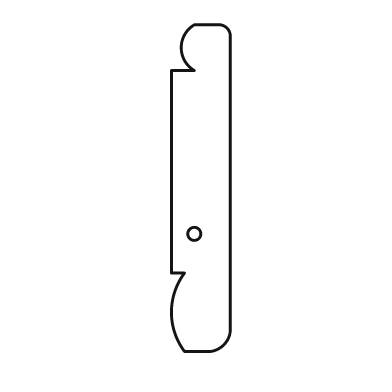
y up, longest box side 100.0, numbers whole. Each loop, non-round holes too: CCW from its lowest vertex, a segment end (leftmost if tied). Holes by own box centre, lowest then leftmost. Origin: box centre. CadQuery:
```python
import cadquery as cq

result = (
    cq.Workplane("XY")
    .moveTo(-5.0, -50.0)
    .lineTo(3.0, -50.0)
    .threePointArc((7.0, -48.0), (9.0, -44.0))
    .lineTo(9.0, 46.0)
    .threePointArc((8.0, 49.0), (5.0, 50.0))
    .lineTo(-2.0, 50.0)
    .threePointArc((-6.0, 43.0), (-2.0, 36.0))
    .lineTo(-9.0, 36.0)
    .lineTo(-9.0, -26.0)
    .lineTo(-5.0, -26.0)
    .threePointArc((-9.0, -38.0), (-5.0, -50.0))
    .close()
    .moveTo(-2.0, -14.0)
    .circle(2.0)
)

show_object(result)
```